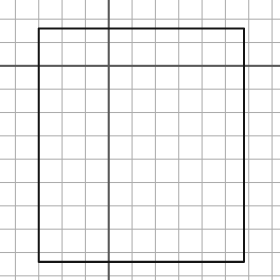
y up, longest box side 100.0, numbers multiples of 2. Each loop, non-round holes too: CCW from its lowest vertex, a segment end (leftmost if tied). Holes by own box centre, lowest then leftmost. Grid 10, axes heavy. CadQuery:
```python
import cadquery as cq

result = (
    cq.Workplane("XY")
    .moveTo(-30.0, -84.0)
    .lineTo(58.0, -84.0)
    .lineTo(58.0, 16.0)
    .lineTo(-30.0, 16.0)
    .close()
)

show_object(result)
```